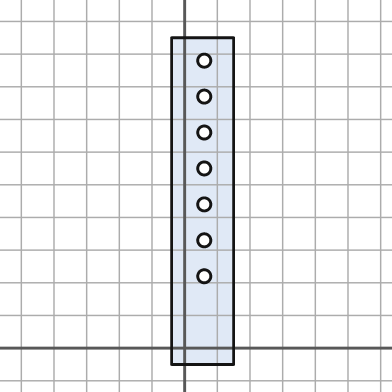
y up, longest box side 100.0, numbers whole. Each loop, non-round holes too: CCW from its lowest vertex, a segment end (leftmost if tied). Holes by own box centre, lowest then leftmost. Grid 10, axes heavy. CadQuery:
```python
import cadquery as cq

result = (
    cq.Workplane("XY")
    .moveTo(-4.0, -5.0)
    .lineTo(15.0, -5.0)
    .lineTo(15.0, 95.0)
    .lineTo(-4.0, 95.0)
    .close()
    .moveTo(6.0, 22.0)
    .circle(2.0)
    .moveTo(6.0, 33.0)
    .circle(2.0)
    .moveTo(6.0, 44.0)
    .circle(2.0)
    .moveTo(6.0, 55.0)
    .circle(2.0)
    .moveTo(6.0, 66.0)
    .circle(2.0)
    .moveTo(6.0, 77.0)
    .circle(2.0)
    .moveTo(6.0, 88.0)
    .circle(2.0)
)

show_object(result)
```